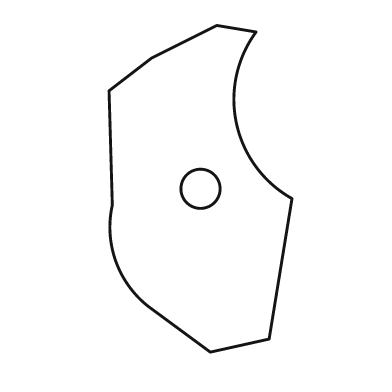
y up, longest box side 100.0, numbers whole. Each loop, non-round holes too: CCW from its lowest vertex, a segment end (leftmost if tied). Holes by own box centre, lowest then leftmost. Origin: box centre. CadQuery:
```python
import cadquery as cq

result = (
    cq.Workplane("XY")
    .moveTo(3.0, -50.0)
    .lineTo(21.0, -46.0)
    .lineTo(28.0, -3.0)
    .threePointArc((11.0, 20.0), (17.0, 48.0))
    .lineTo(5.0, 50.0)
    .lineTo(-15.0, 40.0)
    .lineTo(-28.0, 30.0)
    .lineTo(-27.0, -5.0)
    .threePointArc((-26.0, -22.0), (-16.0, -36.0))
    .close()
    .moveTo(0.0, 0.0)
    .circle(6.0)
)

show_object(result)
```